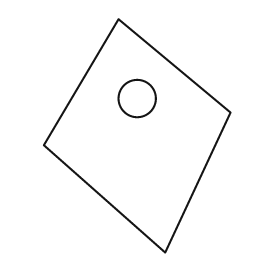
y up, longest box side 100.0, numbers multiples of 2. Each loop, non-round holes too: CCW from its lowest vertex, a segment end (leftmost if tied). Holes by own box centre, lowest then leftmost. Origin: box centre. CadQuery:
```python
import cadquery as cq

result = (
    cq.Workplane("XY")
    .moveTo(12.0, -50.0)
    .lineTo(40.0, 10.0)
    .lineTo(-8.0, 50.0)
    .lineTo(-40.0, -4.0)
    .close()
    .moveTo(0.0, 16.0)
    .circle(8.0)
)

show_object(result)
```